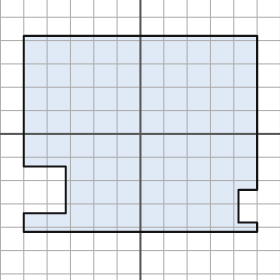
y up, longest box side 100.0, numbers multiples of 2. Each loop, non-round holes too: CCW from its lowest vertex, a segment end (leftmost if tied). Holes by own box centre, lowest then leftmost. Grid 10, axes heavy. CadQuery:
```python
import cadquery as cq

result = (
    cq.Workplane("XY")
    .moveTo(-50.0, -42.0)
    .lineTo(50.0, -42.0)
    .lineTo(50.0, -38.0)
    .lineTo(42.0, -38.0)
    .lineTo(42.0, -24.0)
    .lineTo(50.0, -24.0)
    .lineTo(50.0, 42.0)
    .lineTo(-50.0, 42.0)
    .lineTo(-50.0, -14.0)
    .lineTo(-32.0, -14.0)
    .lineTo(-32.0, -34.0)
    .lineTo(-50.0, -34.0)
    .close()
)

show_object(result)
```